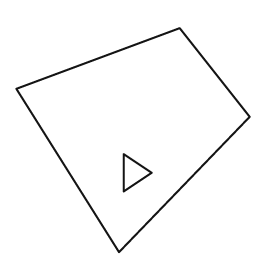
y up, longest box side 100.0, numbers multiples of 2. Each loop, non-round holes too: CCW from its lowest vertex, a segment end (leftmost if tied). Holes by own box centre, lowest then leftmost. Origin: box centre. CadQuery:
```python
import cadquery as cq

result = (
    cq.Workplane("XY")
    .moveTo(-6.0, -48.0)
    .lineTo(50.0, 10.0)
    .lineTo(20.0, 48.0)
    .lineTo(-50.0, 22.0)
    .close()
    .moveTo(-4.0, -22.0)
    .lineTo(8.0, -14.0)
    .lineTo(-4.0, -6.0)
    .close()
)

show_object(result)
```